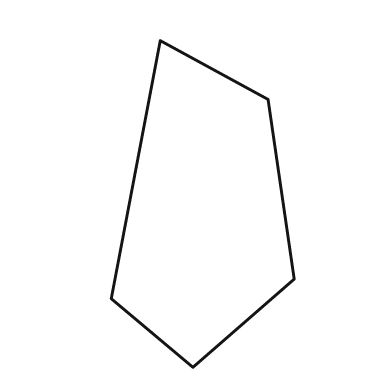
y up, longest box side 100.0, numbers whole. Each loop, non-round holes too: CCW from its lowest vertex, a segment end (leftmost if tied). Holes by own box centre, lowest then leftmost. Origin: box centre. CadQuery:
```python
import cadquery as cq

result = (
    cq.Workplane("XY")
    .moveTo(-3.0, -50.0)
    .lineTo(28.0, -23.0)
    .lineTo(20.0, 32.0)
    .lineTo(-13.0, 50.0)
    .lineTo(-28.0, -29.0)
    .close()
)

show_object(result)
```